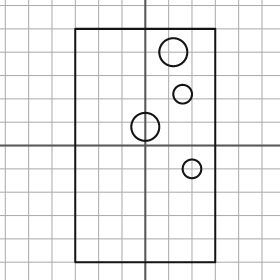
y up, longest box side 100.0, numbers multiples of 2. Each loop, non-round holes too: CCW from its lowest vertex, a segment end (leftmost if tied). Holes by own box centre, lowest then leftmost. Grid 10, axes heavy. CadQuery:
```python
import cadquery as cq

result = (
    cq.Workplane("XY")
    .moveTo(-30.0, -50.0)
    .lineTo(30.0, -50.0)
    .lineTo(30.0, 50.0)
    .lineTo(-30.0, 50.0)
    .close()
    .moveTo(20.0, -10.0)
    .circle(4.0)
    .moveTo(0.0, 8.0)
    .circle(6.0)
    .moveTo(16.0, 22.0)
    .circle(4.0)
    .moveTo(12.0, 40.0)
    .circle(6.0)
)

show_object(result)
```